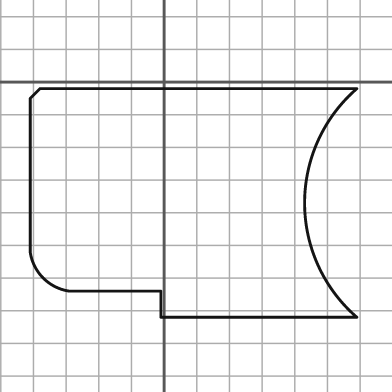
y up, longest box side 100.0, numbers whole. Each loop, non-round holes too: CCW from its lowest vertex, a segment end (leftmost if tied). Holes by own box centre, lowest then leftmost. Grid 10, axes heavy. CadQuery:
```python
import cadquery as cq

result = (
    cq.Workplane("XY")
    .moveTo(-1.0, -72.0)
    .lineTo(59.0, -72.0)
    .threePointArc((43.0, -37.0), (59.0, -2.0))
    .lineTo(-38.0, -2.0)
    .lineTo(-41.0, -5.0)
    .lineTo(-41.0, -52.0)
    .threePointArc((-37.0, -60.0), (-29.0, -64.0))
    .lineTo(-1.0, -64.0)
    .close()
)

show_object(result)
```